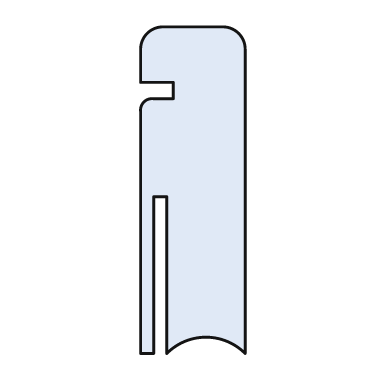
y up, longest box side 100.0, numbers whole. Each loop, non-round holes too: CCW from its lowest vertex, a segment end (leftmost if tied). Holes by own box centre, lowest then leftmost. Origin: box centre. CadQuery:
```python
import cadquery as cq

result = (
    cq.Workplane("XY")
    .moveTo(-16.0, -50.0)
    .lineTo(-12.0, -50.0)
    .lineTo(-12.0, -2.0)
    .lineTo(-8.0, -2.0)
    .lineTo(-8.0, -50.0)
    .threePointArc((4.0, -45.0), (16.0, -50.0))
    .lineTo(16.0, 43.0)
    .threePointArc((14.0, 48.0), (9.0, 50.0))
    .lineTo(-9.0, 50.0)
    .threePointArc((-14.0, 48.0), (-16.0, 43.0))
    .lineTo(-16.0, 33.0)
    .lineTo(-6.0, 33.0)
    .lineTo(-6.0, 28.0)
    .lineTo(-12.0, 28.0)
    .threePointArc((-15.0, 27.0), (-16.0, 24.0))
    .close()
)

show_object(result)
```